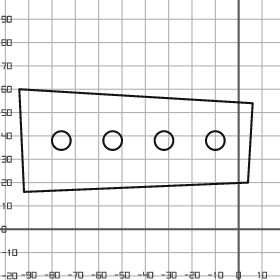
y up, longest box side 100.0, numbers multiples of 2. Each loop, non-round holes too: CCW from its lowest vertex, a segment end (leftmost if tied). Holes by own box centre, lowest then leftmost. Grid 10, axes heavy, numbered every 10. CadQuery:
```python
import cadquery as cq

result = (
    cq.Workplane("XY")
    .moveTo(-92.0, 16.0)
    .lineTo(4.0, 20.0)
    .lineTo(6.0, 54.0)
    .lineTo(-94.0, 60.0)
    .close()
    .moveTo(-76.0, 38.0)
    .circle(4.0)
    .moveTo(-54.0, 38.0)
    .circle(4.0)
    .moveTo(-32.0, 38.0)
    .circle(4.0)
    .moveTo(-10.0, 38.0)
    .circle(4.0)
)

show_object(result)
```